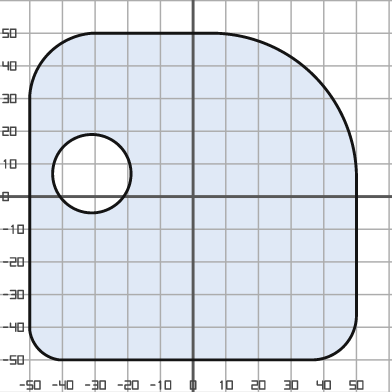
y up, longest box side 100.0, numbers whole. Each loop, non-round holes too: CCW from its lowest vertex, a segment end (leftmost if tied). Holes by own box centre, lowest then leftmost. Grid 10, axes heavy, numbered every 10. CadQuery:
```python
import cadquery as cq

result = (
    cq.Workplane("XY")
    .moveTo(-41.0, -50.0)
    .lineTo(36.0, -50.0)
    .threePointArc((46.0, -46.0), (50.0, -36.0))
    .lineTo(50.0, 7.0)
    .threePointArc((37.0, 37.0), (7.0, 50.0))
    .lineTo(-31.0, 50.0)
    .threePointArc((-44.0, 44.0), (-50.0, 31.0))
    .lineTo(-50.0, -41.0)
    .threePointArc((-47.0, -47.0), (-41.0, -50.0))
    .close()
    .moveTo(-31.0, 7.0)
    .circle(12.0)
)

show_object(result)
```